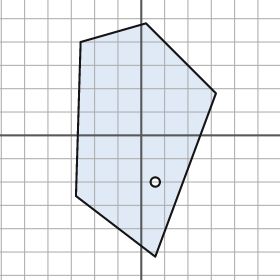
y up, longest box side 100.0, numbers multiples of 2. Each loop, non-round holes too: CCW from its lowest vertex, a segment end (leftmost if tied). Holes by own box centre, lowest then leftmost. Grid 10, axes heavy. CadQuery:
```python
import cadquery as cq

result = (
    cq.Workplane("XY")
    .moveTo(6.0, -52.0)
    .lineTo(32.0, 18.0)
    .lineTo(2.0, 48.0)
    .lineTo(-26.0, 40.0)
    .lineTo(-28.0, -26.0)
    .close()
    .moveTo(6.0, -20.0)
    .circle(2.0)
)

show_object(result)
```